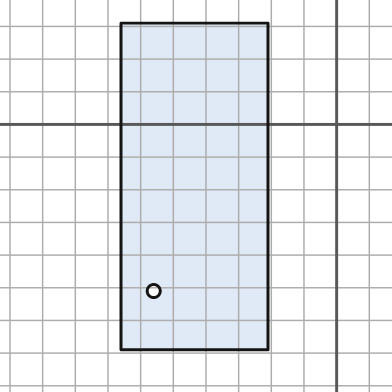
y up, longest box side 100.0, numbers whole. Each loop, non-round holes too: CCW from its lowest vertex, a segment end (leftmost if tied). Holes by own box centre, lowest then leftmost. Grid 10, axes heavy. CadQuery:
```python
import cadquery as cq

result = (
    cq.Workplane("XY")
    .moveTo(-66.0, -69.0)
    .lineTo(-21.0, -69.0)
    .lineTo(-21.0, 31.0)
    .lineTo(-66.0, 31.0)
    .close()
    .moveTo(-56.0, -51.0)
    .circle(2.0)
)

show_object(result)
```